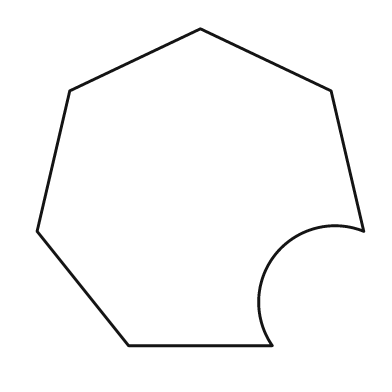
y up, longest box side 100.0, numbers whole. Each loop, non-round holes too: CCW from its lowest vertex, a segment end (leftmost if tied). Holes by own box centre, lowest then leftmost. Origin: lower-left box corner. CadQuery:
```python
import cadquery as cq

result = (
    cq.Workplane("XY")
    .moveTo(28.0, 0.0)
    .lineTo(72.0, 0.0)
    .threePointArc((73.0, 28.0), (100.0, 35.0))
    .lineTo(90.0, 78.0)
    .lineTo(50.0, 97.0)
    .lineTo(10.0, 78.0)
    .lineTo(0.0, 35.0)
    .close()
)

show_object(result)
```